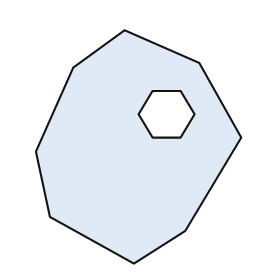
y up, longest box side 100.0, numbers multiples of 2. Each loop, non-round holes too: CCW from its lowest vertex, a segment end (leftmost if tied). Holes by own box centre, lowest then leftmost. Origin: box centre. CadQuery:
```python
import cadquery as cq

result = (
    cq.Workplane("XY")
    .moveTo(-2.0, -50.0)
    .lineTo(20.0, -36.0)
    .lineTo(44.0, 4.0)
    .lineTo(26.0, 36.0)
    .lineTo(-6.0, 50.0)
    .lineTo(-28.0, 34.0)
    .lineTo(-44.0, -2.0)
    .lineTo(-38.0, -30.0)
    .close()
    .moveTo(6.0, 4.0)
    .lineTo(18.0, 4.0)
    .lineTo(24.0, 14.0)
    .lineTo(18.0, 24.0)
    .lineTo(6.0, 24.0)
    .lineTo(0.0, 14.0)
    .close()
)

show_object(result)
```